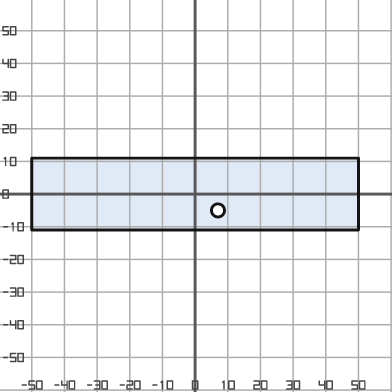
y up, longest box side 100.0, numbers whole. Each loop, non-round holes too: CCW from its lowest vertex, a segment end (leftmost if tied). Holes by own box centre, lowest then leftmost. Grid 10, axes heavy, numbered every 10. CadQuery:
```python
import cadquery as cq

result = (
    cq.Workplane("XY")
    .moveTo(-50.0, -11.0)
    .lineTo(50.0, -11.0)
    .lineTo(50.0, 11.0)
    .lineTo(-50.0, 11.0)
    .close()
    .moveTo(7.0, -5.0)
    .circle(2.0)
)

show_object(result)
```